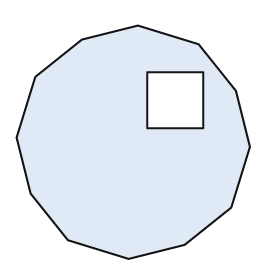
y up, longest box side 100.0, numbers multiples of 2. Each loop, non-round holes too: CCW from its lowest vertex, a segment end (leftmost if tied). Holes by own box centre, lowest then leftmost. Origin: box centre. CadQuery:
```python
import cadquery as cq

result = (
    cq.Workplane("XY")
    .moveTo(-2.0, -50.0)
    .lineTo(22.0, -44.0)
    .lineTo(42.0, -28.0)
    .lineTo(50.0, -2.0)
    .lineTo(44.0, 22.0)
    .lineTo(28.0, 42.0)
    .lineTo(2.0, 50.0)
    .lineTo(-22.0, 44.0)
    .lineTo(-42.0, 28.0)
    .lineTo(-50.0, 2.0)
    .lineTo(-44.0, -22.0)
    .lineTo(-28.0, -42.0)
    .close()
    .moveTo(6.0, 6.0)
    .lineTo(30.0, 6.0)
    .lineTo(30.0, 30.0)
    .lineTo(6.0, 30.0)
    .close()
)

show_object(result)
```